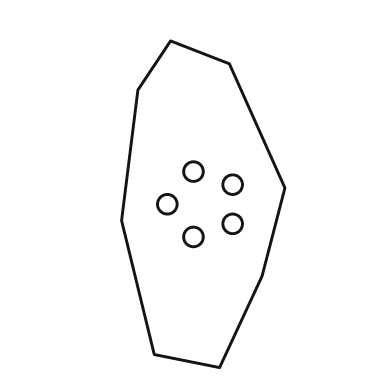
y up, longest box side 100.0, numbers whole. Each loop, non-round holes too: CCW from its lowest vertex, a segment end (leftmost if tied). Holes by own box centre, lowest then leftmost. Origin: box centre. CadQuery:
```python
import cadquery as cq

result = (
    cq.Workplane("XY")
    .moveTo(5.0, -50.0)
    .lineTo(18.0, -22.0)
    .lineTo(25.0, 5.0)
    .lineTo(8.0, 43.0)
    .lineTo(-10.0, 50.0)
    .lineTo(-20.0, 35.0)
    .lineTo(-25.0, -5.0)
    .lineTo(-15.0, -46.0)
    .close()
    .moveTo(-3.0, -10.0)
    .circle(3.0)
    .moveTo(9.0, -6.0)
    .circle(3.0)
    .moveTo(-11.0, 0.0)
    .circle(3.0)
    .moveTo(9.0, 6.0)
    .circle(3.0)
    .moveTo(-3.0, 10.0)
    .circle(3.0)
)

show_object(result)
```